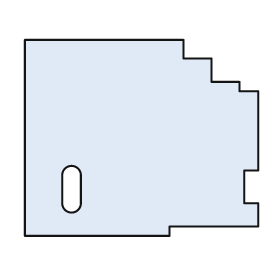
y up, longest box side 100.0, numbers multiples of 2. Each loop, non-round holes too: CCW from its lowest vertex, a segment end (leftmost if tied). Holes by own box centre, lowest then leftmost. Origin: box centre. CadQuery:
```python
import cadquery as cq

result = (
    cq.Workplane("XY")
    .moveTo(-50.0, -42.0)
    .lineTo(12.0, -42.0)
    .lineTo(12.0, -38.0)
    .lineTo(50.0, -38.0)
    .lineTo(50.0, -28.0)
    .lineTo(44.0, -28.0)
    .lineTo(44.0, -14.0)
    .lineTo(50.0, -14.0)
    .lineTo(50.0, 20.0)
    .lineTo(42.0, 20.0)
    .lineTo(42.0, 24.0)
    .lineTo(30.0, 24.0)
    .lineTo(30.0, 34.0)
    .lineTo(18.0, 34.0)
    .lineTo(18.0, 42.0)
    .lineTo(-50.0, 42.0)
    .close()
    .moveTo(-34.0, -28.0)
    .threePointArc((-30.0, -32.0), (-26.0, -28.0))
    .lineTo(-26.0, -16.0)
    .threePointArc((-30.0, -12.0), (-34.0, -16.0))
    .close()
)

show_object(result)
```